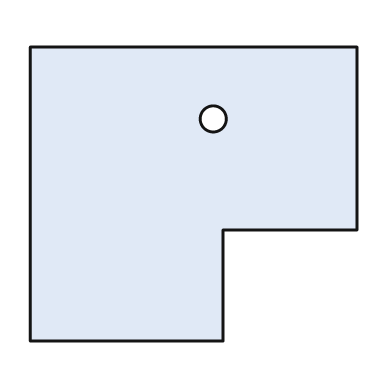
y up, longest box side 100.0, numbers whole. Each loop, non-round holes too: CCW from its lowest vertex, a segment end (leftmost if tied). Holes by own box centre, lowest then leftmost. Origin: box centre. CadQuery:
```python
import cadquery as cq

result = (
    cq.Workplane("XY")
    .moveTo(-50.0, -45.0)
    .lineTo(9.0, -45.0)
    .lineTo(9.0, -11.0)
    .lineTo(50.0, -11.0)
    .lineTo(50.0, 45.0)
    .lineTo(-50.0, 45.0)
    .close()
    .moveTo(6.0, 23.0)
    .circle(4.0)
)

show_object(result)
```